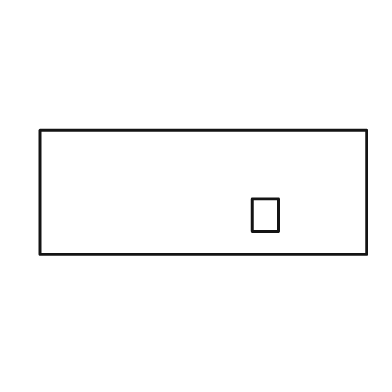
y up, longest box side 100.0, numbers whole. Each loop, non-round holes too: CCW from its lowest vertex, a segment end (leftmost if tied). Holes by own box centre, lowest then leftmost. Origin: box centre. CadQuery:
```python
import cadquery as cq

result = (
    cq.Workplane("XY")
    .moveTo(-50.0, -19.0)
    .lineTo(50.0, -19.0)
    .lineTo(50.0, 19.0)
    .lineTo(-50.0, 19.0)
    .close()
    .moveTo(15.0, -12.0)
    .lineTo(23.0, -12.0)
    .lineTo(23.0, -2.0)
    .lineTo(15.0, -2.0)
    .close()
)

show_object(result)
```